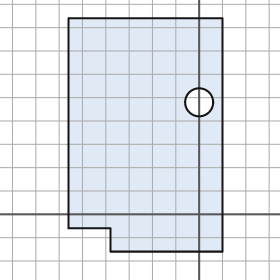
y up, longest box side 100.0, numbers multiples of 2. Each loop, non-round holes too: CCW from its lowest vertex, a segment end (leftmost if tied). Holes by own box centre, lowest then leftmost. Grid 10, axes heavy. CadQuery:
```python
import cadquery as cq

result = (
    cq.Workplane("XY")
    .moveTo(-38.0, -16.0)
    .lineTo(10.0, -16.0)
    .lineTo(10.0, 84.0)
    .lineTo(-56.0, 84.0)
    .lineTo(-56.0, -6.0)
    .lineTo(-38.0, -6.0)
    .close()
    .moveTo(0.0, 48.0)
    .circle(6.0)
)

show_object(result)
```